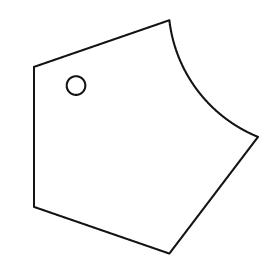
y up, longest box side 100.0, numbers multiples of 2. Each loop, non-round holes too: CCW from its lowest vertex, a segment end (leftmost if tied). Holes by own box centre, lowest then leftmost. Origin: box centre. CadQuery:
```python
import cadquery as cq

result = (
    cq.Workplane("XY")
    .moveTo(10.0, -50.0)
    .lineTo(48.0, 0.0)
    .threePointArc((22.0, 20.0), (10.0, 50.0))
    .lineTo(-48.0, 30.0)
    .lineTo(-48.0, -30.0)
    .close()
    .moveTo(-30.0, 22.0)
    .circle(4.0)
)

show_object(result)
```